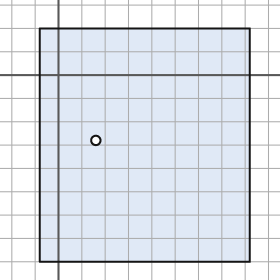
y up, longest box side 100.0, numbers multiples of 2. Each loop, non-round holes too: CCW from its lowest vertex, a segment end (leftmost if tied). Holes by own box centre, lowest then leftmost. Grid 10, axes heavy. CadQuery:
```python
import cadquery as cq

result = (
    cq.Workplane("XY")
    .moveTo(-8.0, -80.0)
    .lineTo(82.0, -80.0)
    .lineTo(82.0, 20.0)
    .lineTo(-8.0, 20.0)
    .close()
    .moveTo(16.0, -28.0)
    .circle(2.0)
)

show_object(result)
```